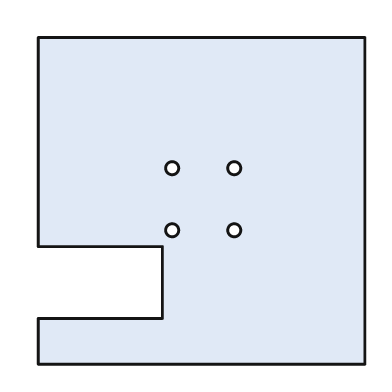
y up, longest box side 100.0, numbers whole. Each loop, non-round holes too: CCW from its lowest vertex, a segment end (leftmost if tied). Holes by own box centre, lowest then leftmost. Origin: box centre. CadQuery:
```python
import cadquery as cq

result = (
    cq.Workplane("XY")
    .moveTo(-50.0, -50.0)
    .lineTo(50.0, -50.0)
    .lineTo(50.0, 50.0)
    .lineTo(-50.0, 50.0)
    .lineTo(-50.0, -14.0)
    .lineTo(-12.0, -14.0)
    .lineTo(-12.0, -36.0)
    .lineTo(-50.0, -36.0)
    .close()
    .moveTo(-9.0, -9.0)
    .circle(2.0)
    .moveTo(10.0, -9.0)
    .circle(2.0)
    .moveTo(-9.0, 10.0)
    .circle(2.0)
    .moveTo(10.0, 10.0)
    .circle(2.0)
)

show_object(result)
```